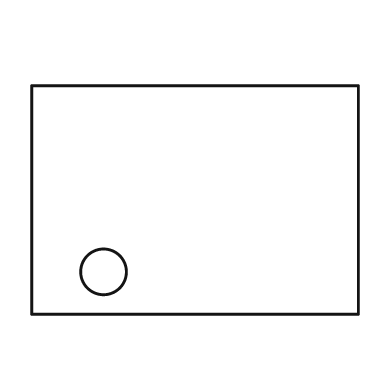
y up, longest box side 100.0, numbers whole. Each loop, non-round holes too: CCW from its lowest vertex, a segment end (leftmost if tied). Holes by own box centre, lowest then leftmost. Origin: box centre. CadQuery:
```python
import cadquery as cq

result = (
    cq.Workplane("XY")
    .moveTo(-50.0, -35.0)
    .lineTo(50.0, -35.0)
    .lineTo(50.0, 35.0)
    .lineTo(-50.0, 35.0)
    .close()
    .moveTo(-28.0, -22.0)
    .circle(7.0)
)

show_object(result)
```